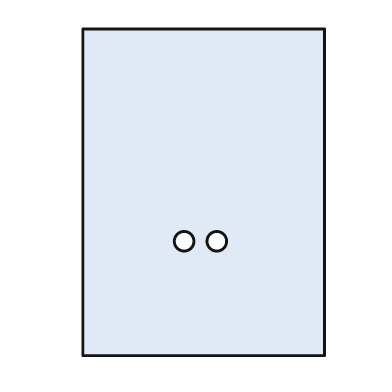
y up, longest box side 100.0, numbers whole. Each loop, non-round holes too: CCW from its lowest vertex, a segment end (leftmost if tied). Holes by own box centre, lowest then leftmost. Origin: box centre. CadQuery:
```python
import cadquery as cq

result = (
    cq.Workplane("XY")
    .moveTo(-37.0, -50.0)
    .lineTo(37.0, -50.0)
    .lineTo(37.0, 50.0)
    .lineTo(-37.0, 50.0)
    .close()
    .moveTo(-6.0, -15.0)
    .circle(3.0)
    .moveTo(4.0, -15.0)
    .circle(3.0)
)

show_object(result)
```